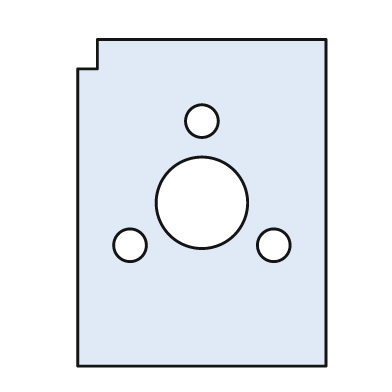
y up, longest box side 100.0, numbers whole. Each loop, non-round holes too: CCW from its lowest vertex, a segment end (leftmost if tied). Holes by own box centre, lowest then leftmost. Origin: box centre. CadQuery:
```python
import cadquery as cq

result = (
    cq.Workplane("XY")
    .moveTo(-38.0, -50.0)
    .lineTo(38.0, -50.0)
    .lineTo(38.0, 50.0)
    .lineTo(-32.0, 50.0)
    .lineTo(-32.0, 41.0)
    .lineTo(-38.0, 41.0)
    .close()
    .moveTo(-22.0, -13.0)
    .circle(5.0)
    .moveTo(22.0, -13.0)
    .circle(5.0)
    .moveTo(0.0, 0.0)
    .circle(14.0)
    .moveTo(0.0, 25.0)
    .circle(5.0)
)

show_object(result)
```